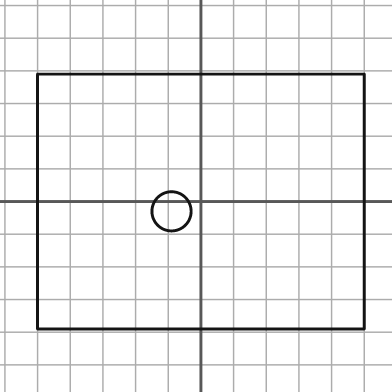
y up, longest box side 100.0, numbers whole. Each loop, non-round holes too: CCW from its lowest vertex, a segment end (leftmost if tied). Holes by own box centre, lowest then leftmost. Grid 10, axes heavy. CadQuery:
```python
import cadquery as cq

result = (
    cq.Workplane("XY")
    .moveTo(-50.0, -39.0)
    .lineTo(50.0, -39.0)
    .lineTo(50.0, 39.0)
    .lineTo(-50.0, 39.0)
    .close()
    .moveTo(-9.0, -3.0)
    .circle(6.0)
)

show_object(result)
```